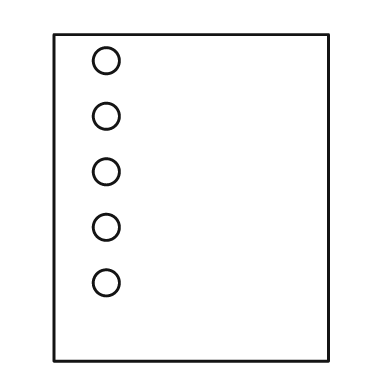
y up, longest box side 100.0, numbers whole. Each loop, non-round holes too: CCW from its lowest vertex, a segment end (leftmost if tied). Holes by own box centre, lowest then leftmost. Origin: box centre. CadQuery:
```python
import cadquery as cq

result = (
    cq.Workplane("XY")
    .moveTo(-42.0, -50.0)
    .lineTo(42.0, -50.0)
    .lineTo(42.0, 50.0)
    .lineTo(-42.0, 50.0)
    .close()
    .moveTo(-26.0, -26.0)
    .circle(4.0)
    .moveTo(-26.0, -9.0)
    .circle(4.0)
    .moveTo(-26.0, 8.0)
    .circle(4.0)
    .moveTo(-26.0, 25.0)
    .circle(4.0)
    .moveTo(-26.0, 42.0)
    .circle(4.0)
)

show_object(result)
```